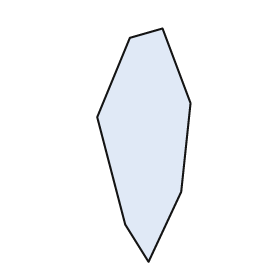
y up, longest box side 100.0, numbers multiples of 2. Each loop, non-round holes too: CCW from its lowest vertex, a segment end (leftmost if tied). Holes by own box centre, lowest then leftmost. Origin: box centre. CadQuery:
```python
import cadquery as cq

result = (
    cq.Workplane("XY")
    .moveTo(2.0, -50.0)
    .lineTo(16.0, -20.0)
    .lineTo(20.0, 18.0)
    .lineTo(8.0, 50.0)
    .lineTo(-6.0, 46.0)
    .lineTo(-20.0, 12.0)
    .lineTo(-8.0, -34.0)
    .close()
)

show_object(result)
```